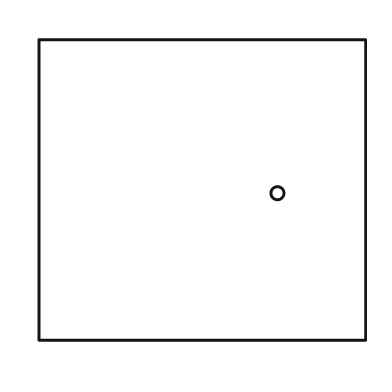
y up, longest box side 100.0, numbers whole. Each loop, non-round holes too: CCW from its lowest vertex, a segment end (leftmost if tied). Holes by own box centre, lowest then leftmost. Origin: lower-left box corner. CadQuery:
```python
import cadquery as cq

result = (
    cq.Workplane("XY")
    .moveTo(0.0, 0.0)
    .lineTo(100.0, 0.0)
    .lineTo(100.0, 92.0)
    .lineTo(0.0, 92.0)
    .close()
    .moveTo(73.0, 45.0)
    .circle(2.0)
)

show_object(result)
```